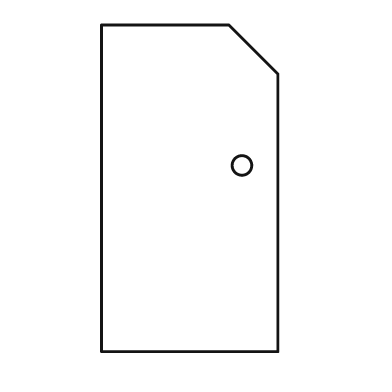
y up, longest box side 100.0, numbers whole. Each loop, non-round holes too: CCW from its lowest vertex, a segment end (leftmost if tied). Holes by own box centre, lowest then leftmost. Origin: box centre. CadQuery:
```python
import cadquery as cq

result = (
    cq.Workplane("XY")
    .moveTo(-27.0, -50.0)
    .lineTo(27.0, -50.0)
    .lineTo(27.0, 35.0)
    .lineTo(12.0, 50.0)
    .lineTo(-27.0, 50.0)
    .close()
    .moveTo(16.0, 7.0)
    .circle(3.0)
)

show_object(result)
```